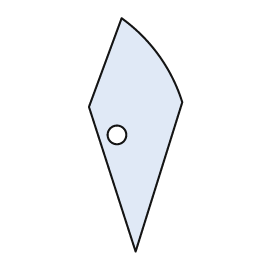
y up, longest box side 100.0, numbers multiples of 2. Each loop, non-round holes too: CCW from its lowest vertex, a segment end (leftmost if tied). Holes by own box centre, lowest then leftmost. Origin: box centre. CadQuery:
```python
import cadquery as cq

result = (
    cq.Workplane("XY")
    .moveTo(0.0, -50.0)
    .lineTo(20.0, 14.0)
    .threePointArc((10.0, 34.0), (-6.0, 50.0))
    .lineTo(-20.0, 12.0)
    .close()
    .moveTo(-8.0, 0.0)
    .circle(4.0)
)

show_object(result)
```